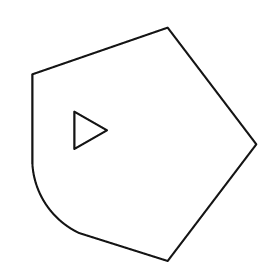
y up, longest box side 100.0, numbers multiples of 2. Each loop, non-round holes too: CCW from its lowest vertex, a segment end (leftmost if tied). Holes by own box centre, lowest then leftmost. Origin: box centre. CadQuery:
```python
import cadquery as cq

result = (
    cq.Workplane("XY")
    .moveTo(10.0, -50.0)
    .lineTo(48.0, 0.0)
    .lineTo(10.0, 50.0)
    .lineTo(-48.0, 30.0)
    .lineTo(-48.0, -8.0)
    .threePointArc((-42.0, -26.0), (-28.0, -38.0))
    .close()
    .moveTo(-30.0, -2.0)
    .lineTo(-16.0, 6.0)
    .lineTo(-30.0, 14.0)
    .close()
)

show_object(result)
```